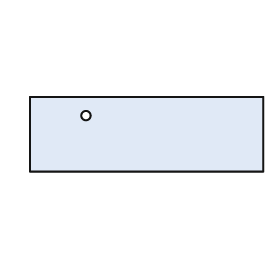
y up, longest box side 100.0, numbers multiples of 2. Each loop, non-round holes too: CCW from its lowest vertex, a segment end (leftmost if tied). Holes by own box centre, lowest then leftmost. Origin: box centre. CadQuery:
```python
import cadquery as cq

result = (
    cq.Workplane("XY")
    .moveTo(-50.0, -16.0)
    .lineTo(50.0, -16.0)
    .lineTo(50.0, 16.0)
    .lineTo(-50.0, 16.0)
    .close()
    .moveTo(-26.0, 8.0)
    .circle(2.0)
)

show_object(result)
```